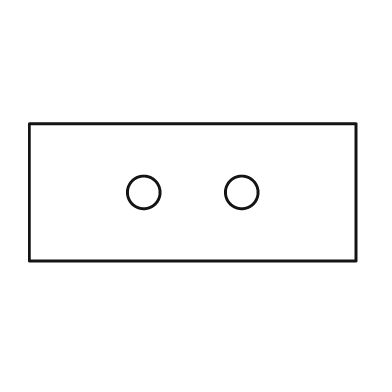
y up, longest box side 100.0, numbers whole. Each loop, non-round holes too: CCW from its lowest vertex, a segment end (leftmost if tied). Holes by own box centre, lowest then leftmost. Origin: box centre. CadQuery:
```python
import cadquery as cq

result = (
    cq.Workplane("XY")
    .moveTo(-50.0, -21.0)
    .lineTo(50.0, -21.0)
    .lineTo(50.0, 21.0)
    .lineTo(-50.0, 21.0)
    .close()
    .moveTo(-15.0, 0.0)
    .circle(5.0)
    .moveTo(15.0, 0.0)
    .circle(5.0)
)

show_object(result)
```